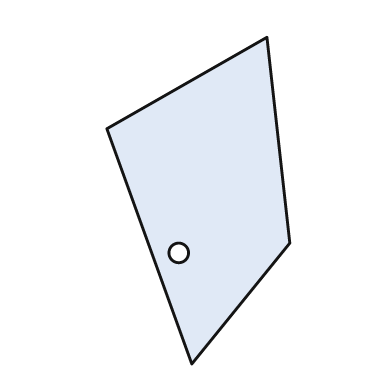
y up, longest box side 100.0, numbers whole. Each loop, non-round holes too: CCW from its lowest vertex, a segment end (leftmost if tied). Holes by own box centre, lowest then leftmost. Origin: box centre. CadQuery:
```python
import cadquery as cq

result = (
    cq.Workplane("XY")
    .moveTo(-2.0, -50.0)
    .lineTo(28.0, -13.0)
    .lineTo(21.0, 50.0)
    .lineTo(-28.0, 22.0)
    .close()
    .moveTo(-6.0, -16.0)
    .circle(3.0)
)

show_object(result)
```